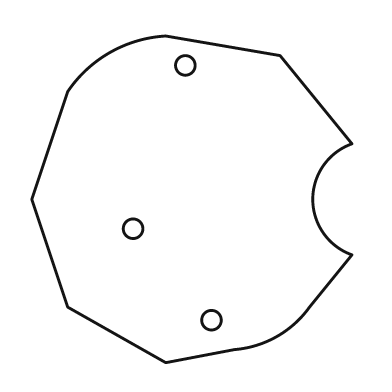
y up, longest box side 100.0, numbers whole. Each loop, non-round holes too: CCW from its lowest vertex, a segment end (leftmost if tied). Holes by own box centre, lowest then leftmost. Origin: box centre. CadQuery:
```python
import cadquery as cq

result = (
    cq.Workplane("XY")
    .moveTo(-8.0, -50.0)
    .lineTo(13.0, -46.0)
    .threePointArc((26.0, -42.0), (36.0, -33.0))
    .lineTo(49.0, -17.0)
    .threePointArc((37.0, 0.0), (49.0, 17.0))
    .lineTo(27.0, 44.0)
    .lineTo(-8.0, 50.0)
    .threePointArc((-25.0, 45.0), (-38.0, 33.0))
    .lineTo(-49.0, 0.0)
    .lineTo(-38.0, -33.0)
    .close()
    .moveTo(6.0, -37.0)
    .circle(3.0)
    .moveTo(-18.0, -9.0)
    .circle(3.0)
    .moveTo(-2.0, 41.0)
    .circle(3.0)
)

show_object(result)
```